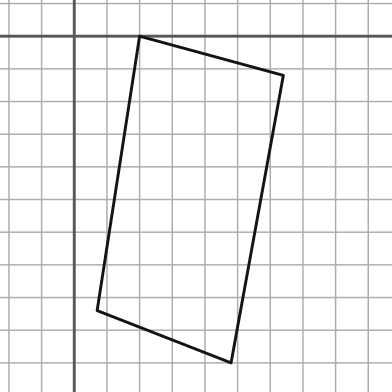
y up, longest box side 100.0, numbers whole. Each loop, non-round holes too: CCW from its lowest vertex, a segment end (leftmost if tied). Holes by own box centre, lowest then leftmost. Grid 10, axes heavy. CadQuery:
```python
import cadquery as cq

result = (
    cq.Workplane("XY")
    .moveTo(48.0, -100.0)
    .lineTo(64.0, -12.0)
    .lineTo(20.0, 0.0)
    .lineTo(7.0, -84.0)
    .close()
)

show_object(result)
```